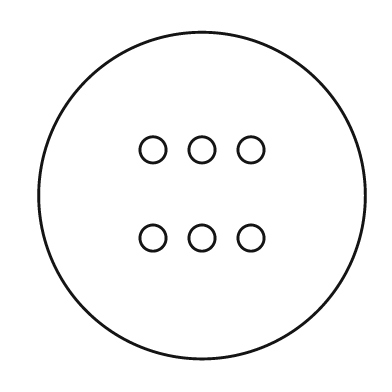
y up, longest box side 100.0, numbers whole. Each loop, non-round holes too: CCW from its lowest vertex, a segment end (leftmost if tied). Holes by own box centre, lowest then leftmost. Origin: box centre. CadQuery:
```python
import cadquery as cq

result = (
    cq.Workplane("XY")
    .moveTo(0.0, 0.0)
    .circle(50.0)
    .moveTo(-15.0, -13.0)
    .circle(4.0)
    .moveTo(0.0, -13.0)
    .circle(4.0)
    .moveTo(15.0, -13.0)
    .circle(4.0)
    .moveTo(-15.0, 14.0)
    .circle(4.0)
    .moveTo(0.0, 14.0)
    .circle(4.0)
    .moveTo(15.0, 14.0)
    .circle(4.0)
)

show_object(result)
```